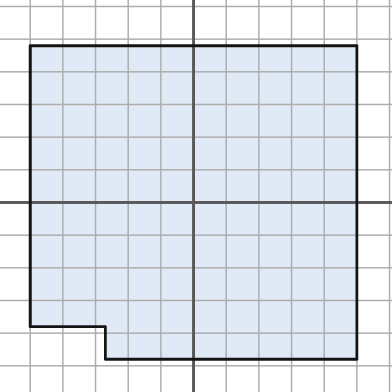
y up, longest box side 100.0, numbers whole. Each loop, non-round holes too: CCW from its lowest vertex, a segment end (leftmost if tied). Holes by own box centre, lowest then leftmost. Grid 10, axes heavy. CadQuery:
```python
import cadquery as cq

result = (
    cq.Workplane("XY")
    .moveTo(-27.0, -48.0)
    .lineTo(50.0, -48.0)
    .lineTo(50.0, 48.0)
    .lineTo(-50.0, 48.0)
    .lineTo(-50.0, -38.0)
    .lineTo(-27.0, -38.0)
    .close()
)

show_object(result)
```